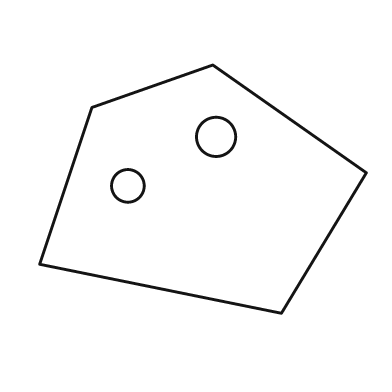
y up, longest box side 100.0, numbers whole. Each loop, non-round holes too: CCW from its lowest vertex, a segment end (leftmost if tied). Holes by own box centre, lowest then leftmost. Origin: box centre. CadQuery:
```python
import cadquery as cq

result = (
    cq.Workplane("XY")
    .moveTo(24.0, -38.0)
    .lineTo(50.0, 5.0)
    .lineTo(3.0, 38.0)
    .lineTo(-34.0, 25.0)
    .lineTo(-50.0, -23.0)
    .close()
    .moveTo(-23.0, 1.0)
    .circle(5.0)
    .moveTo(4.0, 16.0)
    .circle(6.0)
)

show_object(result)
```